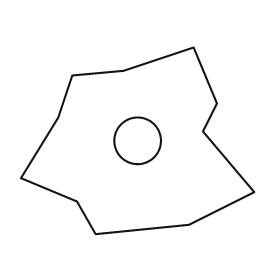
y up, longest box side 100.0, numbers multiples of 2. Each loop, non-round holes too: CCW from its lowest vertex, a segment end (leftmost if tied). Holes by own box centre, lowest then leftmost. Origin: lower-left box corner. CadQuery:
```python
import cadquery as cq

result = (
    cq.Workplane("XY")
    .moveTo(32.0, 0.0)
    .lineTo(72.0, 4.0)
    .lineTo(100.0, 18.0)
    .lineTo(78.0, 44.0)
    .lineTo(84.0, 56.0)
    .lineTo(74.0, 80.0)
    .lineTo(44.0, 70.0)
    .lineTo(22.0, 68.0)
    .lineTo(16.0, 50.0)
    .lineTo(0.0, 24.0)
    .lineTo(24.0, 14.0)
    .close()
    .moveTo(50.0, 40.0)
    .circle(10.0)
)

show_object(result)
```